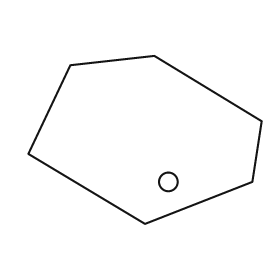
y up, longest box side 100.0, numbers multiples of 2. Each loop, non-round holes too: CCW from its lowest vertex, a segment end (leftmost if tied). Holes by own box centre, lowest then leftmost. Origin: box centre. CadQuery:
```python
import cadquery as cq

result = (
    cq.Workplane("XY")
    .moveTo(0.0, -36.0)
    .lineTo(46.0, -18.0)
    .lineTo(50.0, 8.0)
    .lineTo(4.0, 36.0)
    .lineTo(-32.0, 32.0)
    .lineTo(-50.0, -6.0)
    .close()
    .moveTo(10.0, -18.0)
    .circle(4.0)
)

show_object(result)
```